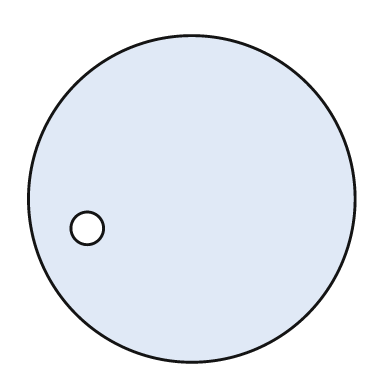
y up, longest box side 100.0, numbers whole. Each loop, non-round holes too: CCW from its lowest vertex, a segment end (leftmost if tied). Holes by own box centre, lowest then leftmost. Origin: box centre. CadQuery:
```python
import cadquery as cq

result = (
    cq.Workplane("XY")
    .moveTo(0.0, 0.0)
    .circle(50.0)
    .moveTo(-32.0, -9.0)
    .circle(5.0)
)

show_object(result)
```